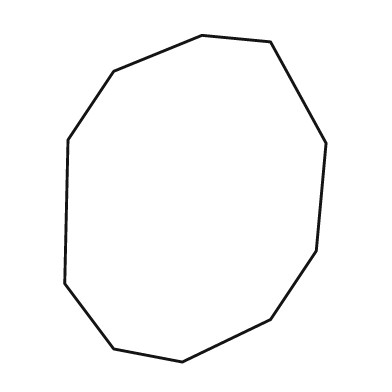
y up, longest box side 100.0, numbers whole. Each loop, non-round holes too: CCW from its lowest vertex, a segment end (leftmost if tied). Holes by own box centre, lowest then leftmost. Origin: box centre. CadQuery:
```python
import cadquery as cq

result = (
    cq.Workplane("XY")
    .moveTo(-4.0, -50.0)
    .lineTo(23.0, -37.0)
    .lineTo(37.0, -16.0)
    .lineTo(40.0, 17.0)
    .lineTo(23.0, 48.0)
    .lineTo(2.0, 50.0)
    .lineTo(-25.0, 39.0)
    .lineTo(-39.0, 18.0)
    .lineTo(-40.0, -26.0)
    .lineTo(-25.0, -46.0)
    .close()
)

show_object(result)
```